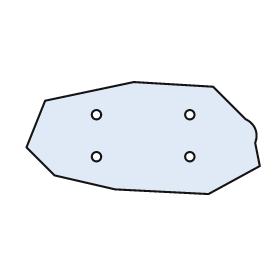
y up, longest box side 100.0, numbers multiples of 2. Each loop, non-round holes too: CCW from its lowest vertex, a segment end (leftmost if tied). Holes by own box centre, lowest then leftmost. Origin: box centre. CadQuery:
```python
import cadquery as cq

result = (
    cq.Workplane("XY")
    .moveTo(28.0, -24.0)
    .lineTo(50.0, -12.0)
    .lineTo(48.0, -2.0)
    .threePointArc((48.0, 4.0), (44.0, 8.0))
    .lineTo(30.0, 22.0)
    .lineTo(-4.0, 24.0)
    .lineTo(-42.0, 16.0)
    .lineTo(-50.0, -4.0)
    .lineTo(-38.0, -16.0)
    .lineTo(-12.0, -22.0)
    .close()
    .moveTo(-20.0, -8.0)
    .circle(2.0)
    .moveTo(20.0, -8.0)
    .circle(2.0)
    .moveTo(-20.0, 10.0)
    .circle(2.0)
    .moveTo(20.0, 10.0)
    .circle(2.0)
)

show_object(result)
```